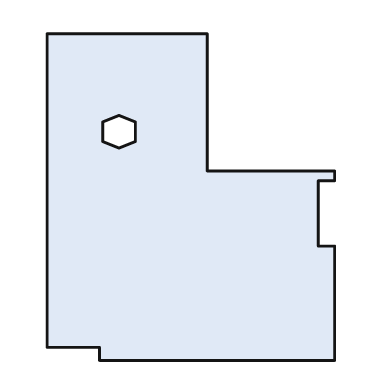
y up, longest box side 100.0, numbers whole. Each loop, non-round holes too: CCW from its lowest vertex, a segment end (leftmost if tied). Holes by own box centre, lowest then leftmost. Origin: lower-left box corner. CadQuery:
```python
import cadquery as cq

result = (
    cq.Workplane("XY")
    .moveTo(16.0, 0.0)
    .lineTo(88.0, 0.0)
    .lineTo(88.0, 35.0)
    .lineTo(83.0, 35.0)
    .lineTo(83.0, 55.0)
    .lineTo(88.0, 55.0)
    .lineTo(88.0, 58.0)
    .lineTo(49.0, 58.0)
    .lineTo(49.0, 100.0)
    .lineTo(0.0, 100.0)
    .lineTo(0.0, 4.0)
    .lineTo(16.0, 4.0)
    .close()
    .moveTo(22.0, 65.0)
    .lineTo(27.0, 67.0)
    .lineTo(27.0, 73.0)
    .lineTo(22.0, 75.0)
    .lineTo(17.0, 73.0)
    .lineTo(17.0, 67.0)
    .close()
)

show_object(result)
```